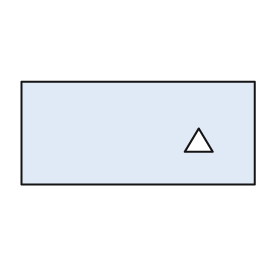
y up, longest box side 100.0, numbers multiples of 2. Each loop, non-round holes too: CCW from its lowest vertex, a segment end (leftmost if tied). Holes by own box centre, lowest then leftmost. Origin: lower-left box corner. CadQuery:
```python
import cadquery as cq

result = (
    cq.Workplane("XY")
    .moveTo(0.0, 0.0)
    .lineTo(100.0, 0.0)
    .lineTo(100.0, 44.0)
    .lineTo(0.0, 44.0)
    .close()
    .moveTo(70.0, 14.0)
    .lineTo(82.0, 14.0)
    .lineTo(76.0, 24.0)
    .close()
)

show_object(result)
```